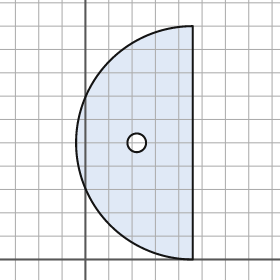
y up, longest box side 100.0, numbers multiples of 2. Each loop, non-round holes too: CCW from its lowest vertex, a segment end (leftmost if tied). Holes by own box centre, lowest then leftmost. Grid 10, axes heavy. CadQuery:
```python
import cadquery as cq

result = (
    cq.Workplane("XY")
    .moveTo(46.0, 0.0)
    .lineTo(46.0, 100.0)
    .threePointArc((-4.0, 50.0), (46.0, 0.0))
    .close()
    .moveTo(22.0, 50.0)
    .circle(4.0)
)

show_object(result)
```